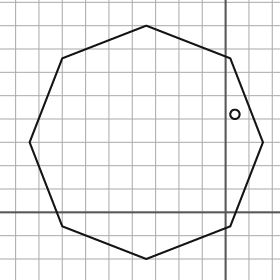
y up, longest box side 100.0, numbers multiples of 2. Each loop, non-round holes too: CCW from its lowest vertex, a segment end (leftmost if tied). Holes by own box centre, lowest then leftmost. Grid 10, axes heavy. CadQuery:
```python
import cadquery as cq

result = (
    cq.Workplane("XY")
    .moveTo(-34.0, -20.0)
    .lineTo(2.0, -6.0)
    .lineTo(16.0, 30.0)
    .lineTo(2.0, 66.0)
    .lineTo(-34.0, 80.0)
    .lineTo(-70.0, 66.0)
    .lineTo(-84.0, 30.0)
    .lineTo(-70.0, -6.0)
    .close()
    .moveTo(4.0, 42.0)
    .circle(2.0)
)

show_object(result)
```